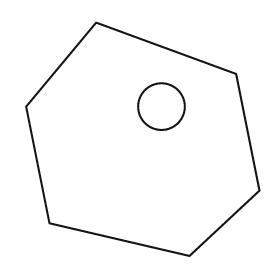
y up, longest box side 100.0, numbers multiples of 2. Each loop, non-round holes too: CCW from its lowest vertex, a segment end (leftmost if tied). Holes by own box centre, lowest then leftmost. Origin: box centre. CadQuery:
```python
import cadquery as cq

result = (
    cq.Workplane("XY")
    .moveTo(20.0, -50.0)
    .lineTo(50.0, -22.0)
    .lineTo(40.0, 28.0)
    .lineTo(-20.0, 50.0)
    .lineTo(-50.0, 14.0)
    .lineTo(-40.0, -36.0)
    .close()
    .moveTo(8.0, 14.0)
    .circle(10.0)
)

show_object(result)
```